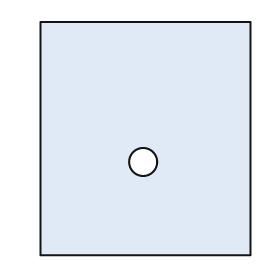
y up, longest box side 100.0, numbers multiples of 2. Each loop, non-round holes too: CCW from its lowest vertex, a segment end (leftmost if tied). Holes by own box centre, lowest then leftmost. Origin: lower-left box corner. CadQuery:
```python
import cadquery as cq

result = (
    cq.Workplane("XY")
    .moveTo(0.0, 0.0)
    .lineTo(90.0, 0.0)
    .lineTo(90.0, 100.0)
    .lineTo(0.0, 100.0)
    .close()
    .moveTo(44.0, 40.0)
    .circle(6.0)
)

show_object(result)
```